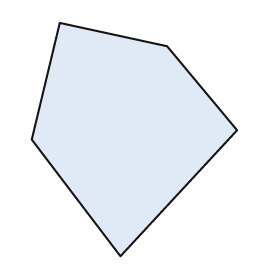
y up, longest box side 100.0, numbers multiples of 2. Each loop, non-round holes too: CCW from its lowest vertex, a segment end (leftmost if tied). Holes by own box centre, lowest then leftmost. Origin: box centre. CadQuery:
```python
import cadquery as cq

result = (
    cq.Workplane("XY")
    .moveTo(-6.0, -50.0)
    .lineTo(44.0, 4.0)
    .lineTo(14.0, 40.0)
    .lineTo(-32.0, 50.0)
    .lineTo(-44.0, 0.0)
    .close()
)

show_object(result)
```